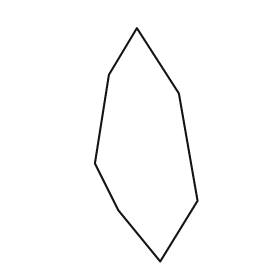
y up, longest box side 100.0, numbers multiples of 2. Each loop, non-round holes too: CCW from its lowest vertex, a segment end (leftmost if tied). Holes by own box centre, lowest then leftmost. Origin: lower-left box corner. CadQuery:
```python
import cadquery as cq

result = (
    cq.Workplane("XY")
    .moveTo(28.0, 0.0)
    .lineTo(44.0, 26.0)
    .lineTo(36.0, 72.0)
    .lineTo(18.0, 100.0)
    .lineTo(6.0, 80.0)
    .lineTo(0.0, 42.0)
    .lineTo(10.0, 22.0)
    .close()
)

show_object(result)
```